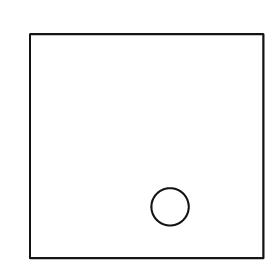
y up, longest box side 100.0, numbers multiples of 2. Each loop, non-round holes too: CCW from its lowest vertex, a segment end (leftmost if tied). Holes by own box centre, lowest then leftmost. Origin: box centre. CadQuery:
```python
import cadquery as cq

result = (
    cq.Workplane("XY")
    .moveTo(-50.0, -48.0)
    .lineTo(50.0, -48.0)
    .lineTo(50.0, 48.0)
    .lineTo(-50.0, 48.0)
    .close()
    .moveTo(10.0, -26.0)
    .circle(8.0)
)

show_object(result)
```